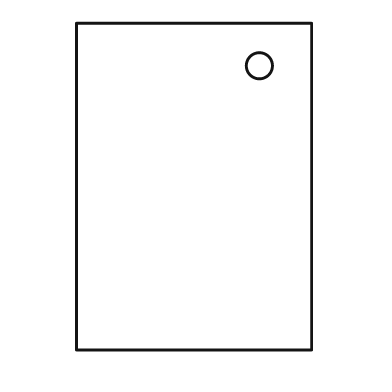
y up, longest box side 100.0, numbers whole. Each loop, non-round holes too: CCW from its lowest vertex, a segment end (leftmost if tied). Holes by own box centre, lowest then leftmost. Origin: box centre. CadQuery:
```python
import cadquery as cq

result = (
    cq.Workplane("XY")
    .moveTo(-36.0, -50.0)
    .lineTo(36.0, -50.0)
    .lineTo(36.0, 50.0)
    .lineTo(-36.0, 50.0)
    .close()
    .moveTo(20.0, 37.0)
    .circle(4.0)
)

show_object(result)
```